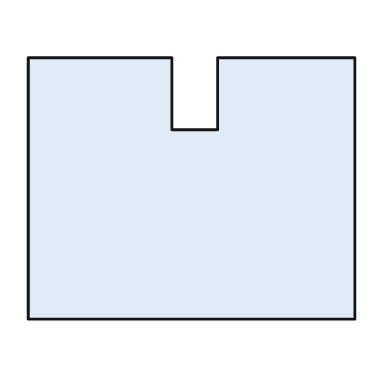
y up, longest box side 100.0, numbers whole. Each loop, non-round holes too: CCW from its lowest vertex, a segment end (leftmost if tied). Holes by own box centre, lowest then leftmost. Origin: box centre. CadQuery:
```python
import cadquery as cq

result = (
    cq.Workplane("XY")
    .moveTo(-50.0, -40.0)
    .lineTo(50.0, -40.0)
    .lineTo(50.0, 40.0)
    .lineTo(8.0, 40.0)
    .lineTo(8.0, 18.0)
    .lineTo(-6.0, 18.0)
    .lineTo(-6.0, 40.0)
    .lineTo(-50.0, 40.0)
    .close()
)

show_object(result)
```